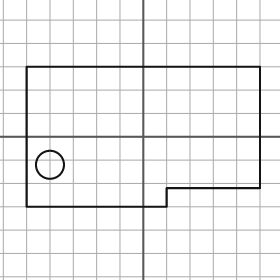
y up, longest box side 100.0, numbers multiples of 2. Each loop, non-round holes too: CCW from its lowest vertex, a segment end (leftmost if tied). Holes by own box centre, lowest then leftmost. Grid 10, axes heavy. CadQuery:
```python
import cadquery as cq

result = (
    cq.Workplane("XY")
    .moveTo(-50.0, -30.0)
    .lineTo(10.0, -30.0)
    .lineTo(10.0, -22.0)
    .lineTo(50.0, -22.0)
    .lineTo(50.0, 30.0)
    .lineTo(-50.0, 30.0)
    .close()
    .moveTo(-40.0, -12.0)
    .circle(6.0)
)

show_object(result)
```